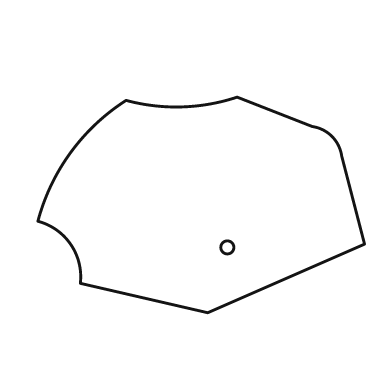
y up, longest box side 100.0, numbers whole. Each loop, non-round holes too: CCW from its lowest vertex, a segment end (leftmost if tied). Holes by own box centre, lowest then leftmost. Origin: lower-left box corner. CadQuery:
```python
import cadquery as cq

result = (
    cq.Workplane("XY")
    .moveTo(52.0, 0.0)
    .lineTo(100.0, 21.0)
    .lineTo(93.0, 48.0)
    .threePointArc((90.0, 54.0), (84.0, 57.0))
    .lineTo(61.0, 66.0)
    .threePointArc((44.0, 63.0), (27.0, 65.0))
    .threePointArc((10.0, 49.0), (0.0, 28.0))
    .threePointArc((10.0, 21.0), (13.0, 9.0))
    .close()
    .moveTo(58.0, 20.0)
    .circle(2.0)
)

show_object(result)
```